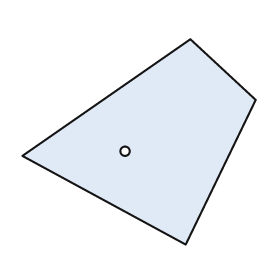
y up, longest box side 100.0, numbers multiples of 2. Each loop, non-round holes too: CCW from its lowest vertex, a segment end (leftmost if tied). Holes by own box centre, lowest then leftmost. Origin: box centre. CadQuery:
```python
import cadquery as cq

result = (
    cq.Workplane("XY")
    .moveTo(20.0, -44.0)
    .lineTo(50.0, 18.0)
    .lineTo(22.0, 44.0)
    .lineTo(-50.0, -6.0)
    .close()
    .moveTo(-6.0, -4.0)
    .circle(2.0)
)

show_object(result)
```